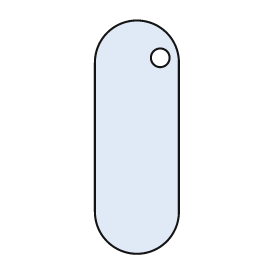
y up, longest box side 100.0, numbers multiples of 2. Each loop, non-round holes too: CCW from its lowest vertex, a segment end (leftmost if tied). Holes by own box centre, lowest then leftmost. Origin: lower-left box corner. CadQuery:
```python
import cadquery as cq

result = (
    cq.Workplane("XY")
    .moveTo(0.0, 18.0)
    .threePointArc((18.0, 0.0), (36.0, 18.0))
    .lineTo(36.0, 82.0)
    .threePointArc((18.0, 100.0), (0.0, 82.0))
    .close()
    .moveTo(28.0, 84.0)
    .circle(4.0)
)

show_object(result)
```